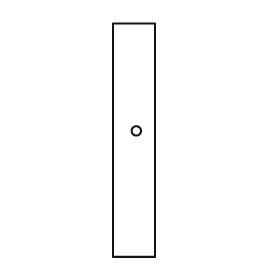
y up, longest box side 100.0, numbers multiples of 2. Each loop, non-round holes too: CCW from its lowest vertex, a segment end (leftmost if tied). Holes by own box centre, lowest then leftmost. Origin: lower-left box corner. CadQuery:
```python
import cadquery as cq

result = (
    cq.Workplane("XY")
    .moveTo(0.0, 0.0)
    .lineTo(18.0, 0.0)
    .lineTo(18.0, 100.0)
    .lineTo(0.0, 100.0)
    .close()
    .moveTo(10.0, 54.0)
    .circle(2.0)
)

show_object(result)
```